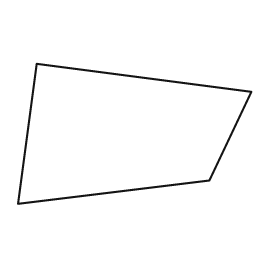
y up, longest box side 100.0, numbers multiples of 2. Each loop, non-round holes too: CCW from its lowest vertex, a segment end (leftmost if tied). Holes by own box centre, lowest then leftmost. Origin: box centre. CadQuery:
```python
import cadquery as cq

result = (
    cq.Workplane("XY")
    .moveTo(-50.0, -30.0)
    .lineTo(32.0, -20.0)
    .lineTo(50.0, 18.0)
    .lineTo(-42.0, 30.0)
    .close()
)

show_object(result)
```